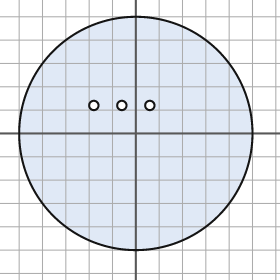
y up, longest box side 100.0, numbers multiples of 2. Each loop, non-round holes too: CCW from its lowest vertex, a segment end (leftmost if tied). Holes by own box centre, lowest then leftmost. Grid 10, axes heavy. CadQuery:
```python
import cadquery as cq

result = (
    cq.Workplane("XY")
    .moveTo(0.0, 0.0)
    .circle(50.0)
    .moveTo(-18.0, 12.0)
    .circle(2.0)
    .moveTo(-6.0, 12.0)
    .circle(2.0)
    .moveTo(6.0, 12.0)
    .circle(2.0)
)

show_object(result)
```